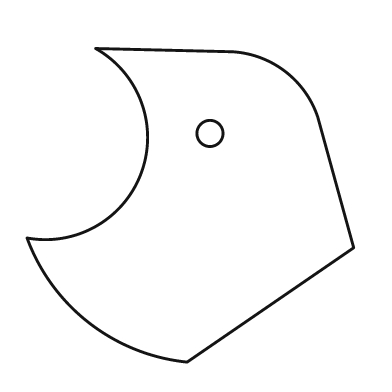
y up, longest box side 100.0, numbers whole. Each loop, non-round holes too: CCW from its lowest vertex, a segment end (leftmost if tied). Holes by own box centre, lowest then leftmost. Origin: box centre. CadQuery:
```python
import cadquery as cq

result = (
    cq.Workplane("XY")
    .moveTo(-1.0, -48.0)
    .lineTo(50.0, -13.0)
    .lineTo(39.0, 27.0)
    .threePointArc((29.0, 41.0), (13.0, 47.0))
    .lineTo(-29.0, 48.0)
    .threePointArc((-15.0, 10.0), (-50.0, -10.0))
    .threePointArc((-31.0, -36.0), (-1.0, -48.0))
    .close()
    .moveTo(6.0, 22.0)
    .circle(4.0)
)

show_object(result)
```